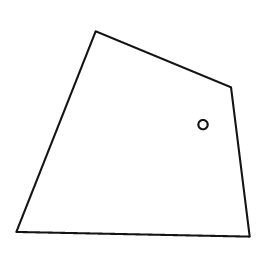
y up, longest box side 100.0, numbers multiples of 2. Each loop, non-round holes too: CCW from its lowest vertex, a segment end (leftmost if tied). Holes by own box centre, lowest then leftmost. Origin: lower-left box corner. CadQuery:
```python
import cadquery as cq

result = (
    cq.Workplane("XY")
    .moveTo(100.0, 0.0)
    .lineTo(92.0, 64.0)
    .lineTo(34.0, 88.0)
    .lineTo(0.0, 2.0)
    .close()
    .moveTo(80.0, 48.0)
    .circle(2.0)
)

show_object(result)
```